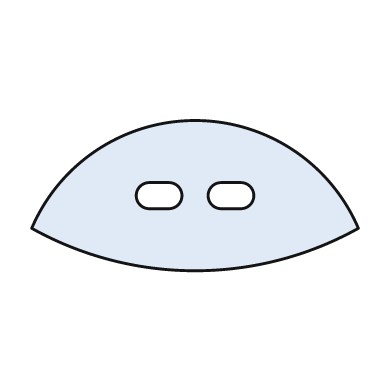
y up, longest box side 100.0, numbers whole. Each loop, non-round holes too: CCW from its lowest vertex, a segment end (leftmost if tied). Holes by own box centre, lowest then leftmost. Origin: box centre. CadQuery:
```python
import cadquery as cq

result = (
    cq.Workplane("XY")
    .moveTo(-50.0, -10.0)
    .threePointArc((0.0, -23.0), (50.0, -10.0))
    .threePointArc((0.0, 23.0), (-50.0, -10.0))
    .close()
    .moveTo(-14.0, -4.0)
    .lineTo(-8.0, -4.0)
    .threePointArc((-4.0, 0.0), (-8.0, 4.0))
    .lineTo(-14.0, 4.0)
    .threePointArc((-18.0, 0.0), (-14.0, -4.0))
    .close()
    .moveTo(8.0, -4.0)
    .lineTo(14.0, -4.0)
    .threePointArc((18.0, 0.0), (14.0, 4.0))
    .lineTo(8.0, 4.0)
    .threePointArc((4.0, 0.0), (8.0, -4.0))
    .close()
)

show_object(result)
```